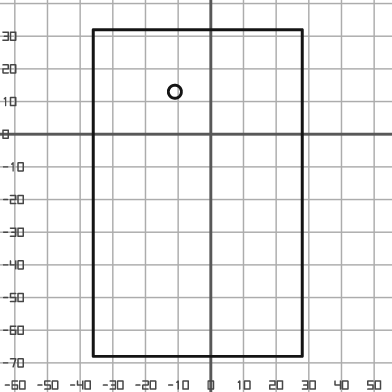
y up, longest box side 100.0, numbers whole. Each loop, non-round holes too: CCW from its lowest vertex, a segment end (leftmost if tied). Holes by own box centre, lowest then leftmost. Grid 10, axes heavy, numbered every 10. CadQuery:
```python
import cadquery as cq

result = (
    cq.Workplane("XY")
    .moveTo(-36.0, -68.0)
    .lineTo(28.0, -68.0)
    .lineTo(28.0, 32.0)
    .lineTo(-36.0, 32.0)
    .close()
    .moveTo(-11.0, 13.0)
    .circle(2.0)
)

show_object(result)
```